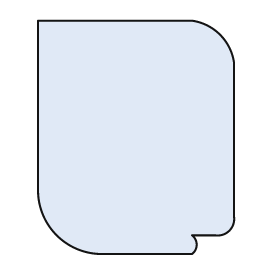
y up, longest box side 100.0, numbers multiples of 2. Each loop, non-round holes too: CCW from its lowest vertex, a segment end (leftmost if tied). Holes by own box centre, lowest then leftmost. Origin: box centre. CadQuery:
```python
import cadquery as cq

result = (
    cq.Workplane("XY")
    .moveTo(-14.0, -50.0)
    .lineTo(24.0, -50.0)
    .threePointArc((26.0, -46.0), (24.0, -42.0))
    .lineTo(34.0, -42.0)
    .threePointArc((40.0, -40.0), (42.0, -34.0))
    .lineTo(42.0, 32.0)
    .threePointArc((36.0, 44.0), (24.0, 50.0))
    .lineTo(-42.0, 50.0)
    .lineTo(-42.0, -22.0)
    .threePointArc((-34.0, -42.0), (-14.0, -50.0))
    .close()
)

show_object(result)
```